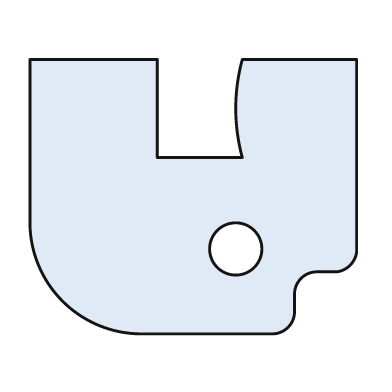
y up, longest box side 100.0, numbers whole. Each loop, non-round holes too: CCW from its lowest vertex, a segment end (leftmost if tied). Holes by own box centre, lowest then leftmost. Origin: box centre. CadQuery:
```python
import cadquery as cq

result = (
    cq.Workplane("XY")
    .moveTo(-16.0, -42.0)
    .lineTo(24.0, -42.0)
    .threePointArc((29.0, -40.0), (31.0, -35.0))
    .lineTo(31.0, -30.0)
    .threePointArc((33.0, -25.0), (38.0, -23.0))
    .lineTo(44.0, -23.0)
    .threePointArc((48.0, -21.0), (50.0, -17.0))
    .lineTo(50.0, 42.0)
    .lineTo(15.0, 42.0)
    .threePointArc((13.0, 27.0), (15.0, 12.0))
    .lineTo(-11.0, 12.0)
    .lineTo(-11.0, 42.0)
    .lineTo(-50.0, 42.0)
    .lineTo(-50.0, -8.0)
    .threePointArc((-40.0, -32.0), (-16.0, -42.0))
    .close()
    .moveTo(13.0, -16.0)
    .circle(8.0)
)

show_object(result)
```